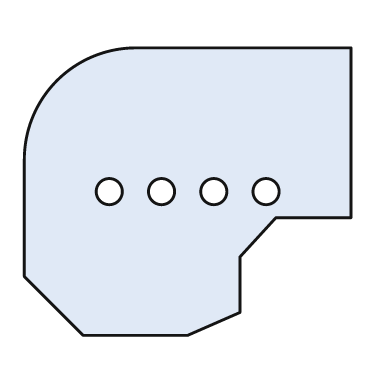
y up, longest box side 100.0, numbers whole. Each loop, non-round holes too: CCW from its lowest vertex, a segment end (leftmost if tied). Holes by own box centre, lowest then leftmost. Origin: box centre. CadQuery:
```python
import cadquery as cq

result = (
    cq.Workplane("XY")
    .moveTo(-32.0, -44.0)
    .lineTo(0.0, -44.0)
    .lineTo(16.0, -37.0)
    .lineTo(16.0, -20.0)
    .lineTo(27.0, -8.0)
    .lineTo(50.0, -8.0)
    .lineTo(50.0, 44.0)
    .lineTo(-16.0, 44.0)
    .threePointArc((-40.0, 34.0), (-50.0, 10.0))
    .lineTo(-50.0, -26.0)
    .close()
    .moveTo(-24.0, 0.0)
    .circle(4.0)
    .moveTo(-8.0, 0.0)
    .circle(4.0)
    .moveTo(8.0, 0.0)
    .circle(4.0)
    .moveTo(24.0, 0.0)
    .circle(4.0)
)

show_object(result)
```